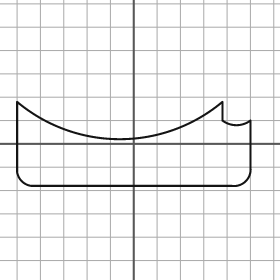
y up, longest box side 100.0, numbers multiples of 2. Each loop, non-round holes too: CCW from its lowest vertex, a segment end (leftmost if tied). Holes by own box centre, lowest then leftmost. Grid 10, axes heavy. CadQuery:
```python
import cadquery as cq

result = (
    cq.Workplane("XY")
    .moveTo(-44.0, -18.0)
    .lineTo(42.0, -18.0)
    .threePointArc((48.0, -16.0), (50.0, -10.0))
    .lineTo(50.0, 10.0)
    .threePointArc((44.0, 8.0), (38.0, 10.0))
    .lineTo(38.0, 18.0)
    .threePointArc((-6.0, 2.0), (-50.0, 18.0))
    .lineTo(-50.0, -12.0)
    .threePointArc((-48.0, -16.0), (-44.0, -18.0))
    .close()
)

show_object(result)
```